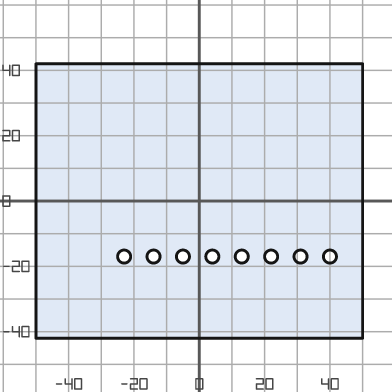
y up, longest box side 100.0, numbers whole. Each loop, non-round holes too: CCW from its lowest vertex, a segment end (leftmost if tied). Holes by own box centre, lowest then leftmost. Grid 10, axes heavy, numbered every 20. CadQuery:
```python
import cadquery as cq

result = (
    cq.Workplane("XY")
    .moveTo(-50.0, -42.0)
    .lineTo(50.0, -42.0)
    .lineTo(50.0, 42.0)
    .lineTo(-50.0, 42.0)
    .close()
    .moveTo(-23.0, -17.0)
    .circle(2.0)
    .moveTo(-14.0, -17.0)
    .circle(2.0)
    .moveTo(-5.0, -17.0)
    .circle(2.0)
    .moveTo(4.0, -17.0)
    .circle(2.0)
    .moveTo(13.0, -17.0)
    .circle(2.0)
    .moveTo(22.0, -17.0)
    .circle(2.0)
    .moveTo(31.0, -17.0)
    .circle(2.0)
    .moveTo(40.0, -17.0)
    .circle(2.0)
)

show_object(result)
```